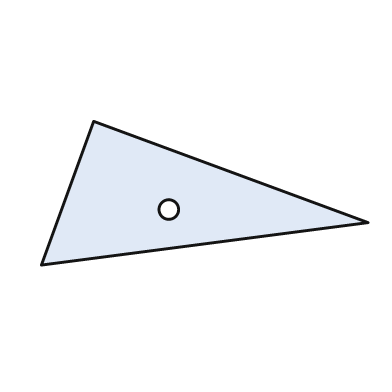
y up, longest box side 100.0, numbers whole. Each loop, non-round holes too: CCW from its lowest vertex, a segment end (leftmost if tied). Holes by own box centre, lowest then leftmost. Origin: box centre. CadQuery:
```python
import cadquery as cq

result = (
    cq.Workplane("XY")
    .moveTo(-50.0, -22.0)
    .lineTo(50.0, -9.0)
    .lineTo(-34.0, 22.0)
    .close()
    .moveTo(-11.0, -5.0)
    .circle(3.0)
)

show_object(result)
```